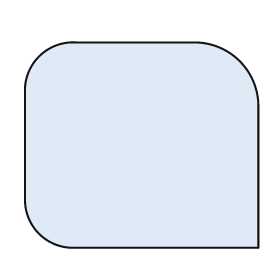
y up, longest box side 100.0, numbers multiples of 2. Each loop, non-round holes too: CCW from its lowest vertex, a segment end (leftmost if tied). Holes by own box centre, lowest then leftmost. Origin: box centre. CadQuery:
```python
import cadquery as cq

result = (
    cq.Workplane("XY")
    .moveTo(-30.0, -44.0)
    .lineTo(50.0, -44.0)
    .lineTo(50.0, 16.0)
    .threePointArc((42.0, 36.0), (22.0, 44.0))
    .lineTo(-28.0, 44.0)
    .threePointArc((-44.0, 38.0), (-50.0, 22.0))
    .lineTo(-50.0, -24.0)
    .threePointArc((-44.0, -38.0), (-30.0, -44.0))
    .close()
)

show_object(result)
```